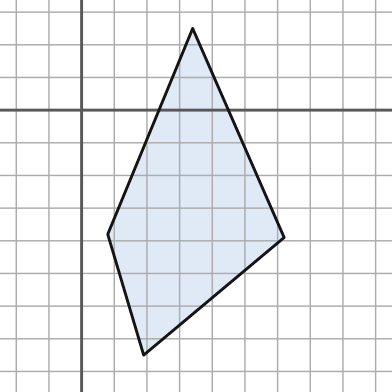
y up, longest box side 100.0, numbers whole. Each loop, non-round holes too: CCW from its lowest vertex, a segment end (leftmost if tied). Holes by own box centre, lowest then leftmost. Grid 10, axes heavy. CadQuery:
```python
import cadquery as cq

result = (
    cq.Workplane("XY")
    .moveTo(19.0, -75.0)
    .lineTo(62.0, -39.0)
    .lineTo(34.0, 25.0)
    .lineTo(8.0, -38.0)
    .close()
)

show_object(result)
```